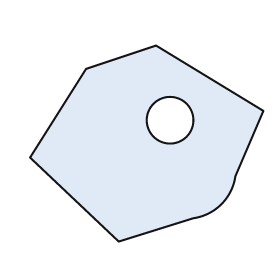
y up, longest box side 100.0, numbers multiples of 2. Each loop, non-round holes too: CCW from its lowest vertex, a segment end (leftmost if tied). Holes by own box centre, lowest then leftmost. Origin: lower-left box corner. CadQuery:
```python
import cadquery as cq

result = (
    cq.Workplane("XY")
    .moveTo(38.0, 0.0)
    .lineTo(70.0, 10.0)
    .threePointArc((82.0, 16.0), (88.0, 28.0))
    .lineTo(100.0, 56.0)
    .lineTo(54.0, 84.0)
    .lineTo(24.0, 74.0)
    .lineTo(0.0, 36.0)
    .close()
    .moveTo(60.0, 52.0)
    .circle(10.0)
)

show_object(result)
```